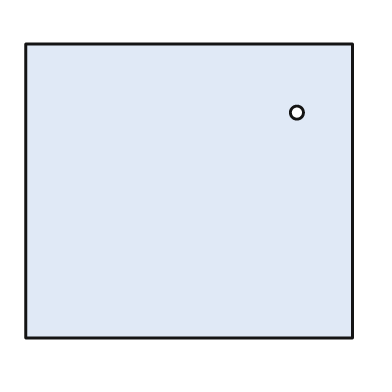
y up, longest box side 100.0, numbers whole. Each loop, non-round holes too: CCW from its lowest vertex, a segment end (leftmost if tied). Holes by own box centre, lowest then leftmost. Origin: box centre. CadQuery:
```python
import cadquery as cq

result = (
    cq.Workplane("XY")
    .moveTo(-50.0, -45.0)
    .lineTo(50.0, -45.0)
    .lineTo(50.0, 45.0)
    .lineTo(-50.0, 45.0)
    .close()
    .moveTo(33.0, 24.0)
    .circle(2.0)
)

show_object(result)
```